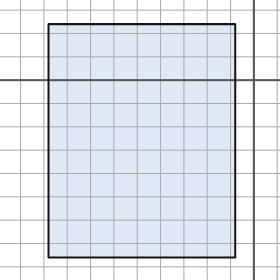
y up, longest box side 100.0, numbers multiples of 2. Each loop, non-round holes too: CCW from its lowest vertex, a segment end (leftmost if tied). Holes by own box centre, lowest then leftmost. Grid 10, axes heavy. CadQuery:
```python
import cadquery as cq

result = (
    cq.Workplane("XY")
    .moveTo(-88.0, -76.0)
    .lineTo(-8.0, -76.0)
    .lineTo(-8.0, 24.0)
    .lineTo(-88.0, 24.0)
    .close()
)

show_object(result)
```